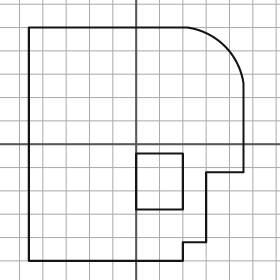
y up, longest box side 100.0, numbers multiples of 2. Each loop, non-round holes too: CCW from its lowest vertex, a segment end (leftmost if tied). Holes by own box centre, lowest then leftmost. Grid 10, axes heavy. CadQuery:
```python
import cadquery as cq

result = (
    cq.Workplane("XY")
    .moveTo(-46.0, -50.0)
    .lineTo(20.0, -50.0)
    .lineTo(20.0, -42.0)
    .lineTo(30.0, -42.0)
    .lineTo(30.0, -12.0)
    .lineTo(46.0, -12.0)
    .lineTo(46.0, 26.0)
    .threePointArc((38.0, 42.0), (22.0, 50.0))
    .lineTo(-46.0, 50.0)
    .close()
    .moveTo(0.0, -28.0)
    .lineTo(20.0, -28.0)
    .lineTo(20.0, -4.0)
    .lineTo(0.0, -4.0)
    .close()
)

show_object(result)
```